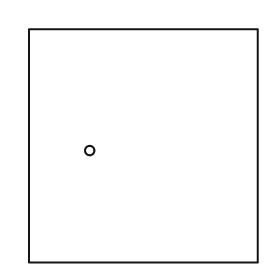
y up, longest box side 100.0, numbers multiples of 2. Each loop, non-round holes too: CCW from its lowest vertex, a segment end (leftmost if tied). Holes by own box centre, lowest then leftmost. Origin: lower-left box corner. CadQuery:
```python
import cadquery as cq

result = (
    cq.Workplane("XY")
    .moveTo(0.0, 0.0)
    .lineTo(98.0, 0.0)
    .lineTo(98.0, 100.0)
    .lineTo(0.0, 100.0)
    .close()
    .moveTo(26.0, 48.0)
    .circle(2.0)
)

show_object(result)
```